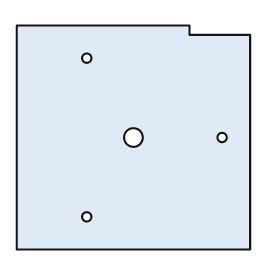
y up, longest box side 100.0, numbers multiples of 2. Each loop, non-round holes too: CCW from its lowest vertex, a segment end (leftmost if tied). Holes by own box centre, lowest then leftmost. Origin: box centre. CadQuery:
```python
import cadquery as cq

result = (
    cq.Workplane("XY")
    .moveTo(-50.0, -48.0)
    .lineTo(50.0, -48.0)
    .lineTo(50.0, 44.0)
    .lineTo(24.0, 44.0)
    .lineTo(24.0, 48.0)
    .lineTo(-50.0, 48.0)
    .close()
    .moveTo(-20.0, -34.0)
    .circle(2.0)
    .moveTo(0.0, 0.0)
    .circle(4.0)
    .moveTo(38.0, 0.0)
    .circle(2.0)
    .moveTo(-20.0, 34.0)
    .circle(2.0)
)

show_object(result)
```